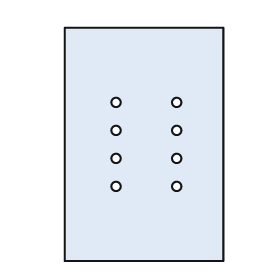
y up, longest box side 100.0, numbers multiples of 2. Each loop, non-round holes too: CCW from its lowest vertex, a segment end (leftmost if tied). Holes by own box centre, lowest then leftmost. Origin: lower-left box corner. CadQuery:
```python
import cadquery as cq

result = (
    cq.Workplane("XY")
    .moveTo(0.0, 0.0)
    .lineTo(68.0, 0.0)
    .lineTo(68.0, 100.0)
    .lineTo(0.0, 100.0)
    .close()
    .moveTo(22.0, 32.0)
    .circle(2.0)
    .moveTo(48.0, 32.0)
    .circle(2.0)
    .moveTo(22.0, 44.0)
    .circle(2.0)
    .moveTo(48.0, 44.0)
    .circle(2.0)
    .moveTo(22.0, 56.0)
    .circle(2.0)
    .moveTo(48.0, 56.0)
    .circle(2.0)
    .moveTo(22.0, 68.0)
    .circle(2.0)
    .moveTo(48.0, 68.0)
    .circle(2.0)
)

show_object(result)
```